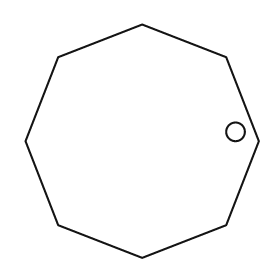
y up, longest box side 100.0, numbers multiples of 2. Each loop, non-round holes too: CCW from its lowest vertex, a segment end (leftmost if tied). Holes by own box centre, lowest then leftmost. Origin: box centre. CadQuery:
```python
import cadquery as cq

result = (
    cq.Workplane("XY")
    .moveTo(0.0, -50.0)
    .lineTo(36.0, -36.0)
    .lineTo(50.0, 0.0)
    .lineTo(36.0, 36.0)
    .lineTo(0.0, 50.0)
    .lineTo(-36.0, 36.0)
    .lineTo(-50.0, 0.0)
    .lineTo(-36.0, -36.0)
    .close()
    .moveTo(40.0, 4.0)
    .circle(4.0)
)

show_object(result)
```